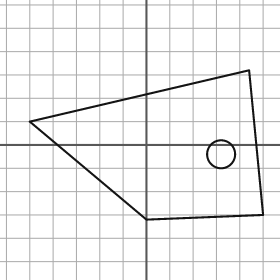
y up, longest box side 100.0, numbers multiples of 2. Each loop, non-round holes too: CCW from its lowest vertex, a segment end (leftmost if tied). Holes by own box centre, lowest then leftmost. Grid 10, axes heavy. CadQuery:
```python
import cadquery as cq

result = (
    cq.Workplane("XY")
    .moveTo(0.0, -32.0)
    .lineTo(50.0, -30.0)
    .lineTo(44.0, 32.0)
    .lineTo(-50.0, 10.0)
    .close()
    .moveTo(32.0, -4.0)
    .circle(6.0)
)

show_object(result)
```